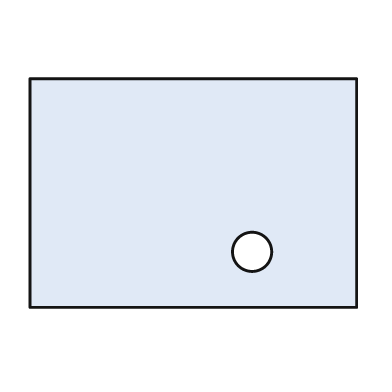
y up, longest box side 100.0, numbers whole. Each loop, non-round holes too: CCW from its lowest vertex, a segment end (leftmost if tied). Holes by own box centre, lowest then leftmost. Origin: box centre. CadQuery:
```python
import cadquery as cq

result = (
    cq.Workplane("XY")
    .moveTo(-50.0, -35.0)
    .lineTo(50.0, -35.0)
    .lineTo(50.0, 35.0)
    .lineTo(-50.0, 35.0)
    .close()
    .moveTo(18.0, -18.0)
    .circle(6.0)
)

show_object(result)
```